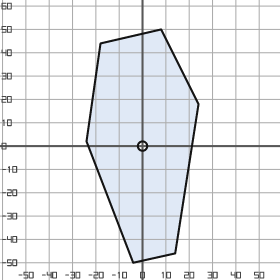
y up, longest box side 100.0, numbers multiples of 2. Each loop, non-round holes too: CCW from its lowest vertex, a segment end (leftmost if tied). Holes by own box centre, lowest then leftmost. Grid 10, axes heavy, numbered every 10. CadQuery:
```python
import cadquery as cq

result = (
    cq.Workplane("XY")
    .moveTo(-4.0, -50.0)
    .lineTo(14.0, -46.0)
    .lineTo(24.0, 18.0)
    .lineTo(8.0, 50.0)
    .lineTo(-18.0, 44.0)
    .lineTo(-24.0, 2.0)
    .close()
    .moveTo(0.0, 0.0)
    .circle(2.0)
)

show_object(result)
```